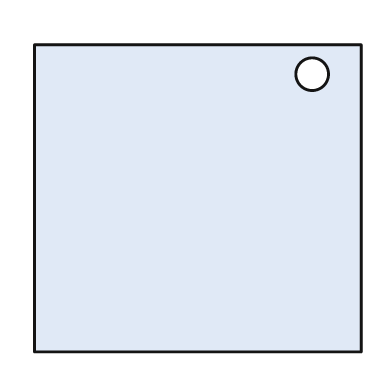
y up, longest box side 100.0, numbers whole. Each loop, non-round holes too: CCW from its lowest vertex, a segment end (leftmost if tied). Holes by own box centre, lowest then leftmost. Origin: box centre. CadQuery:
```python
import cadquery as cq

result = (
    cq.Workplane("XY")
    .moveTo(-50.0, -47.0)
    .lineTo(50.0, -47.0)
    .lineTo(50.0, 47.0)
    .lineTo(-50.0, 47.0)
    .close()
    .moveTo(35.0, 38.0)
    .circle(5.0)
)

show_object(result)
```